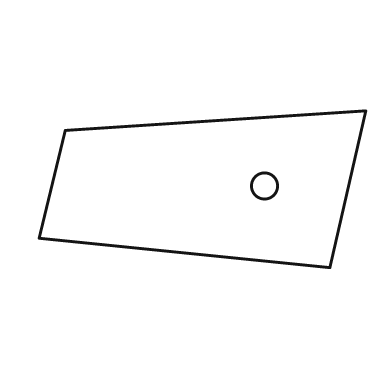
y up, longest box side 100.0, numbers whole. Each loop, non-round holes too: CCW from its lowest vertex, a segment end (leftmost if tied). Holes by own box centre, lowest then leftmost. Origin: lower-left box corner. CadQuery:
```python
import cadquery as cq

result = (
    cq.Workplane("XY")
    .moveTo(89.0, 0.0)
    .lineTo(100.0, 48.0)
    .lineTo(8.0, 42.0)
    .lineTo(0.0, 9.0)
    .close()
    .moveTo(69.0, 25.0)
    .circle(4.0)
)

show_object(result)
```